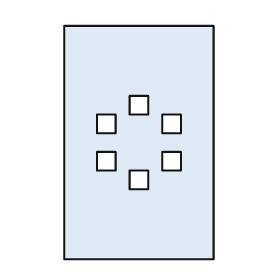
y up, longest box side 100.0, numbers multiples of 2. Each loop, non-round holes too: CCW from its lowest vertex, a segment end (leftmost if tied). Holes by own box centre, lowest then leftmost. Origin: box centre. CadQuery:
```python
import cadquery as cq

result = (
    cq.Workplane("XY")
    .moveTo(-32.0, -50.0)
    .lineTo(32.0, -50.0)
    .lineTo(32.0, 50.0)
    .lineTo(-32.0, 50.0)
    .close()
    .moveTo(-4.0, -20.0)
    .lineTo(4.0, -20.0)
    .lineTo(4.0, -12.0)
    .lineTo(-4.0, -12.0)
    .close()
    .moveTo(-18.0, -12.0)
    .lineTo(-10.0, -12.0)
    .lineTo(-10.0, -4.0)
    .lineTo(-18.0, -4.0)
    .close()
    .moveTo(10.0, -12.0)
    .lineTo(18.0, -12.0)
    .lineTo(18.0, -4.0)
    .lineTo(10.0, -4.0)
    .close()
    .moveTo(-18.0, 4.0)
    .lineTo(-10.0, 4.0)
    .lineTo(-10.0, 12.0)
    .lineTo(-18.0, 12.0)
    .close()
    .moveTo(10.0, 4.0)
    .lineTo(18.0, 4.0)
    .lineTo(18.0, 12.0)
    .lineTo(10.0, 12.0)
    .close()
    .moveTo(-4.0, 12.0)
    .lineTo(4.0, 12.0)
    .lineTo(4.0, 20.0)
    .lineTo(-4.0, 20.0)
    .close()
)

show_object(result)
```